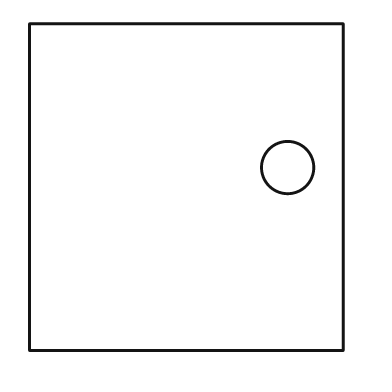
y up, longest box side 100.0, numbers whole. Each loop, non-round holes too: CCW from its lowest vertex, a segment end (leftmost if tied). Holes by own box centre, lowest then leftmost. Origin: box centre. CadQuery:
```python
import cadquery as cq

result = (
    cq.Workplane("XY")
    .moveTo(-48.0, -50.0)
    .lineTo(48.0, -50.0)
    .lineTo(48.0, 50.0)
    .lineTo(-48.0, 50.0)
    .close()
    .moveTo(31.0, 6.0)
    .circle(8.0)
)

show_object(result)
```